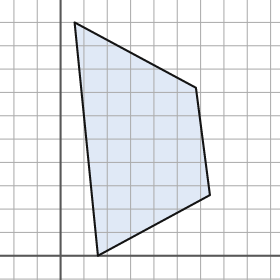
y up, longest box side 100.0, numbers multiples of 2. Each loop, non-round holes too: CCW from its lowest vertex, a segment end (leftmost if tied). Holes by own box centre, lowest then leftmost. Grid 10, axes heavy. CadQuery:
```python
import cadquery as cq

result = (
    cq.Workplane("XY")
    .moveTo(16.0, 0.0)
    .lineTo(64.0, 26.0)
    .lineTo(58.0, 72.0)
    .lineTo(6.0, 100.0)
    .close()
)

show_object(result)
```